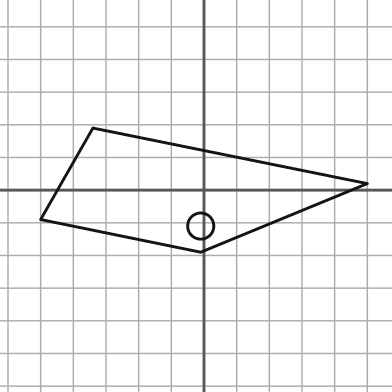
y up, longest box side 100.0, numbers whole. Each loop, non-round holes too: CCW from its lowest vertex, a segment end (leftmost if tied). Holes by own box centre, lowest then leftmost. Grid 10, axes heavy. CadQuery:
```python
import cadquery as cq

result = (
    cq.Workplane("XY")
    .moveTo(-1.0, -19.0)
    .lineTo(50.0, 2.0)
    .lineTo(-34.0, 19.0)
    .lineTo(-50.0, -9.0)
    .close()
    .moveTo(-1.0, -11.0)
    .circle(4.0)
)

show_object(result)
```